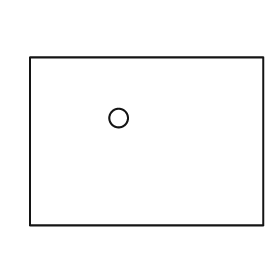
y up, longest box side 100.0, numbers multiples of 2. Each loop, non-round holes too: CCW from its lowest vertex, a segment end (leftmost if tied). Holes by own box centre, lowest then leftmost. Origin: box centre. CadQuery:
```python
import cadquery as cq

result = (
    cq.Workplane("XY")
    .moveTo(-50.0, -36.0)
    .lineTo(50.0, -36.0)
    .lineTo(50.0, 36.0)
    .lineTo(-50.0, 36.0)
    .close()
    .moveTo(-12.0, 10.0)
    .circle(4.0)
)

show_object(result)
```